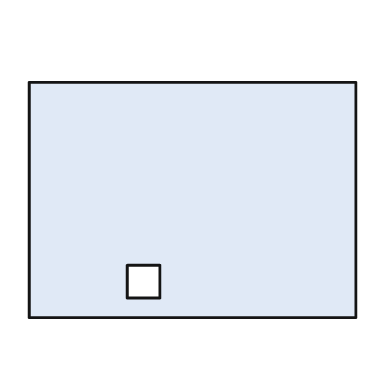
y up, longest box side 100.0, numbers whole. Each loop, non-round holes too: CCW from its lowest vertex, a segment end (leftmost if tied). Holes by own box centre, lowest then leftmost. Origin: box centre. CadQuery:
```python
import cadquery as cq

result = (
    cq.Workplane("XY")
    .moveTo(-50.0, -36.0)
    .lineTo(50.0, -36.0)
    .lineTo(50.0, 36.0)
    .lineTo(-50.0, 36.0)
    .close()
    .moveTo(-20.0, -30.0)
    .lineTo(-10.0, -30.0)
    .lineTo(-10.0, -20.0)
    .lineTo(-20.0, -20.0)
    .close()
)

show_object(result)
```